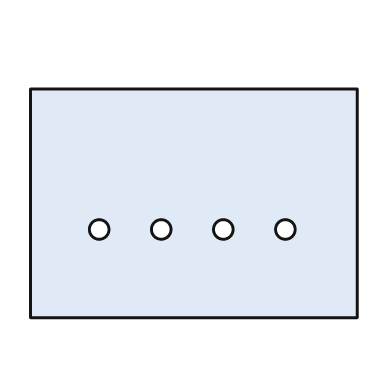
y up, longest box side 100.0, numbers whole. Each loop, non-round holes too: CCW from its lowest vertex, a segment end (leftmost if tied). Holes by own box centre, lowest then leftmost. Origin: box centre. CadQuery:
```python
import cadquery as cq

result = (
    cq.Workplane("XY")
    .moveTo(-50.0, -35.0)
    .lineTo(50.0, -35.0)
    .lineTo(50.0, 35.0)
    .lineTo(-50.0, 35.0)
    .close()
    .moveTo(-29.0, -8.0)
    .circle(3.0)
    .moveTo(-10.0, -8.0)
    .circle(3.0)
    .moveTo(9.0, -8.0)
    .circle(3.0)
    .moveTo(28.0, -8.0)
    .circle(3.0)
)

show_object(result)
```